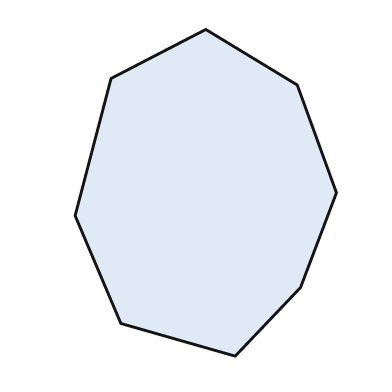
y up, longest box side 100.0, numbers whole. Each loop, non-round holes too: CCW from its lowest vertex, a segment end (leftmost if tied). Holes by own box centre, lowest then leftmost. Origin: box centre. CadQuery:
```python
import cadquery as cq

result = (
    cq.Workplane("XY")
    .moveTo(9.0, -50.0)
    .lineTo(29.0, -29.0)
    .lineTo(40.0, 0.0)
    .lineTo(28.0, 33.0)
    .lineTo(0.0, 50.0)
    .lineTo(-29.0, 35.0)
    .lineTo(-40.0, -7.0)
    .lineTo(-26.0, -40.0)
    .close()
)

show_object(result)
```